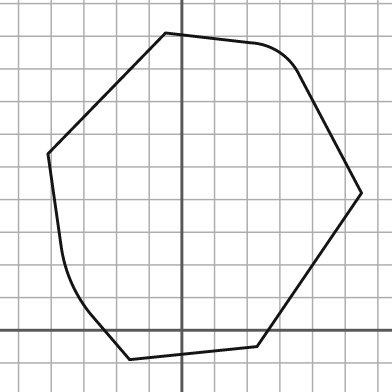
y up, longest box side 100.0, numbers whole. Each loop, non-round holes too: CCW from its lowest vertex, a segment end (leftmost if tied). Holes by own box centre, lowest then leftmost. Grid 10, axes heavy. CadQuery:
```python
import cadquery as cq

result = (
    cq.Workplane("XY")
    .moveTo(-16.0, -9.0)
    .lineTo(23.0, -5.0)
    .lineTo(55.0, 42.0)
    .lineTo(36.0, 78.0)
    .threePointArc((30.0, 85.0), (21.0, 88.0))
    .lineTo(-5.0, 91.0)
    .lineTo(-41.0, 54.0)
    .lineTo(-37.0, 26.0)
    .threePointArc((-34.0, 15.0), (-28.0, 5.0))
    .close()
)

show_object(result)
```